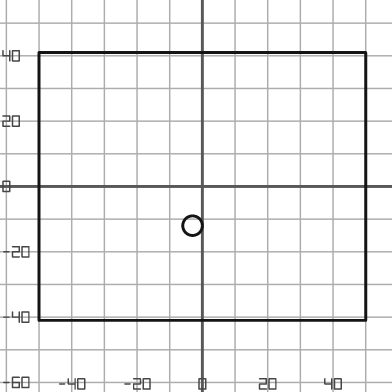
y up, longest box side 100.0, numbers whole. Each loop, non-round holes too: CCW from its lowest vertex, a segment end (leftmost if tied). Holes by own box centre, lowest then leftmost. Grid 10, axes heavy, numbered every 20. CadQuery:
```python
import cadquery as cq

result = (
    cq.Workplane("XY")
    .moveTo(-50.0, -41.0)
    .lineTo(50.0, -41.0)
    .lineTo(50.0, 41.0)
    .lineTo(-50.0, 41.0)
    .close()
    .moveTo(-3.0, -12.0)
    .circle(3.0)
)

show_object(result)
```